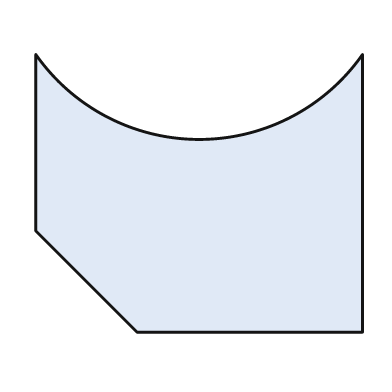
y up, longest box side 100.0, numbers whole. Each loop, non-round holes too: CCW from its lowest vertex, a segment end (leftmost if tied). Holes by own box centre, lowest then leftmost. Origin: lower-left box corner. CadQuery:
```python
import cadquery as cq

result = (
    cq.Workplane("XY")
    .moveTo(31.0, 0.0)
    .lineTo(100.0, 0.0)
    .lineTo(100.0, 85.0)
    .threePointArc((50.0, 59.0), (0.0, 85.0))
    .lineTo(0.0, 31.0)
    .close()
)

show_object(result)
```